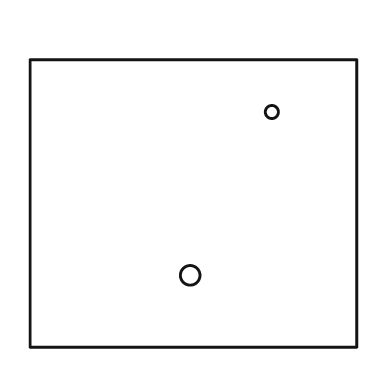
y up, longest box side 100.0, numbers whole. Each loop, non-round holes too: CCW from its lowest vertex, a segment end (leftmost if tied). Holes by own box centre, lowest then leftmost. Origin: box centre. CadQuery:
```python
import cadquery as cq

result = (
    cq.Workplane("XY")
    .moveTo(-50.0, -44.0)
    .lineTo(50.0, -44.0)
    .lineTo(50.0, 44.0)
    .lineTo(-50.0, 44.0)
    .close()
    .moveTo(-1.0, -22.0)
    .circle(3.0)
    .moveTo(24.0, 28.0)
    .circle(2.0)
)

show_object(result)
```